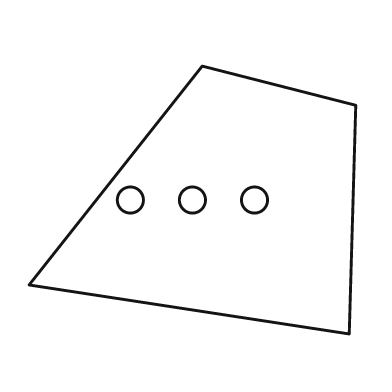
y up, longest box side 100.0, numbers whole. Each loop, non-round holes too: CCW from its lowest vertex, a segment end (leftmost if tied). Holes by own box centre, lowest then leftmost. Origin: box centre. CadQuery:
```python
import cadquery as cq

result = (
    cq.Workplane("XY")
    .moveTo(48.0, -41.0)
    .lineTo(50.0, 29.0)
    .lineTo(3.0, 41.0)
    .lineTo(-50.0, -26.0)
    .close()
    .moveTo(-19.0, 0.0)
    .circle(4.0)
    .moveTo(0.0, 0.0)
    .circle(4.0)
    .moveTo(19.0, 0.0)
    .circle(4.0)
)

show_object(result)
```